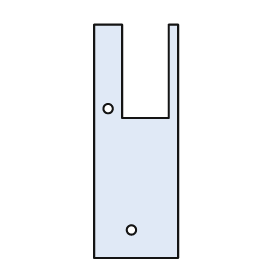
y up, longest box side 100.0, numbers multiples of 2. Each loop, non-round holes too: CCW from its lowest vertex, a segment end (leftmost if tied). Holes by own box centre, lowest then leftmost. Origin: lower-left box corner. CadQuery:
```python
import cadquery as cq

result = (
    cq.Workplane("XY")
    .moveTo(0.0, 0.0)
    .lineTo(36.0, 0.0)
    .lineTo(36.0, 100.0)
    .lineTo(32.0, 100.0)
    .lineTo(32.0, 60.0)
    .lineTo(12.0, 60.0)
    .lineTo(12.0, 100.0)
    .lineTo(0.0, 100.0)
    .close()
    .moveTo(16.0, 12.0)
    .circle(2.0)
    .moveTo(6.0, 64.0)
    .circle(2.0)
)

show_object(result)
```